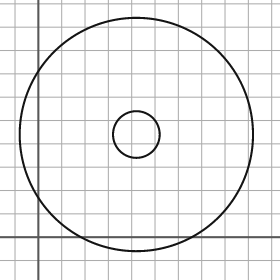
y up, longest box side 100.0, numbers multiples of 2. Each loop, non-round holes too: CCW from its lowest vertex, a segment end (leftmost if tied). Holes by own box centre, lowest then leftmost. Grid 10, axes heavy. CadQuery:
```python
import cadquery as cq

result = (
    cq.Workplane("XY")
    .moveTo(42.0, 44.0)
    .circle(50.0)
    .moveTo(42.0, 44.0)
    .circle(10.0)
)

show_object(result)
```